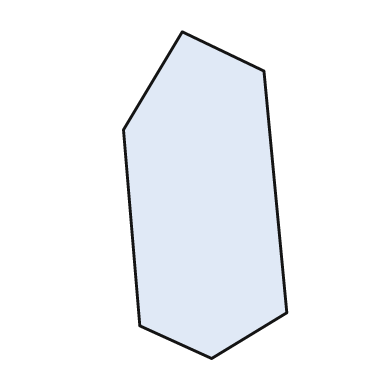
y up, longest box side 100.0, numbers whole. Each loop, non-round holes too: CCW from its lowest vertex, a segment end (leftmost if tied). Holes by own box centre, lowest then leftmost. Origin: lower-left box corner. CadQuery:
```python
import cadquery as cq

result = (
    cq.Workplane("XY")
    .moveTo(27.0, 0.0)
    .lineTo(50.0, 14.0)
    .lineTo(43.0, 88.0)
    .lineTo(18.0, 100.0)
    .lineTo(0.0, 70.0)
    .lineTo(5.0, 10.0)
    .close()
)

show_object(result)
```